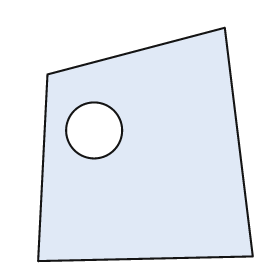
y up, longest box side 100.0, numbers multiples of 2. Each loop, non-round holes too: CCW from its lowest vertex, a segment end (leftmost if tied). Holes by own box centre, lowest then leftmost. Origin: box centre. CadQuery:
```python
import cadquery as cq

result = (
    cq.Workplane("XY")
    .moveTo(-46.0, -50.0)
    .lineTo(46.0, -48.0)
    .lineTo(34.0, 50.0)
    .lineTo(-42.0, 30.0)
    .close()
    .moveTo(-22.0, 6.0)
    .circle(12.0)
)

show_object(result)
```